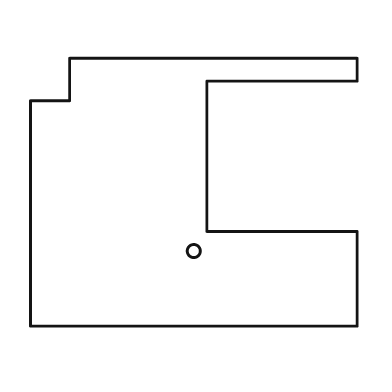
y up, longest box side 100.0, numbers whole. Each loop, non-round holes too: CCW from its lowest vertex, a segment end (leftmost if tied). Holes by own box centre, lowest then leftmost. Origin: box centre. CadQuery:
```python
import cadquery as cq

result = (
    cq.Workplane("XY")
    .moveTo(-50.0, -41.0)
    .lineTo(50.0, -41.0)
    .lineTo(50.0, -12.0)
    .lineTo(4.0, -12.0)
    .lineTo(4.0, 34.0)
    .lineTo(50.0, 34.0)
    .lineTo(50.0, 41.0)
    .lineTo(-38.0, 41.0)
    .lineTo(-38.0, 28.0)
    .lineTo(-50.0, 28.0)
    .close()
    .moveTo(0.0, -18.0)
    .circle(2.0)
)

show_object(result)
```